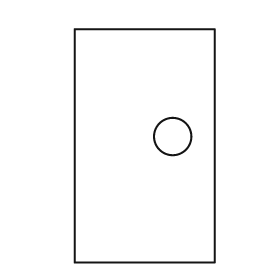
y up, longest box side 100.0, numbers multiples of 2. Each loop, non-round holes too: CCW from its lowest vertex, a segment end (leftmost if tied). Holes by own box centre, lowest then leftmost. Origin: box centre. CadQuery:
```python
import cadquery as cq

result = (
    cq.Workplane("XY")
    .moveTo(-30.0, -50.0)
    .lineTo(30.0, -50.0)
    .lineTo(30.0, 50.0)
    .lineTo(-30.0, 50.0)
    .close()
    .moveTo(12.0, 4.0)
    .circle(8.0)
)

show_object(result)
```